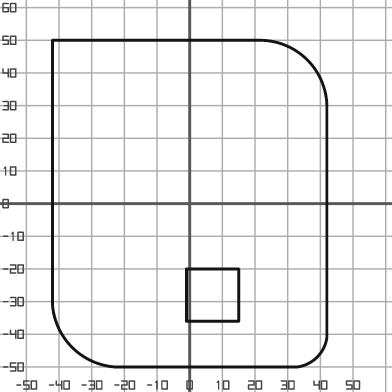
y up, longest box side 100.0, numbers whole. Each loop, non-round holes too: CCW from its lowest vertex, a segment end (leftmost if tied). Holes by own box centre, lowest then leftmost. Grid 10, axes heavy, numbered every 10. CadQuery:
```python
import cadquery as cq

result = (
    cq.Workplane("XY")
    .moveTo(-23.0, -50.0)
    .lineTo(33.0, -50.0)
    .threePointArc((39.0, -47.0), (42.0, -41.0))
    .lineTo(42.0, 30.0)
    .threePointArc((36.0, 44.0), (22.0, 50.0))
    .lineTo(-42.0, 50.0)
    .lineTo(-42.0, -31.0)
    .threePointArc((-36.0, -44.0), (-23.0, -50.0))
    .close()
    .moveTo(-1.0, -36.0)
    .lineTo(15.0, -36.0)
    .lineTo(15.0, -20.0)
    .lineTo(-1.0, -20.0)
    .close()
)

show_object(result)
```